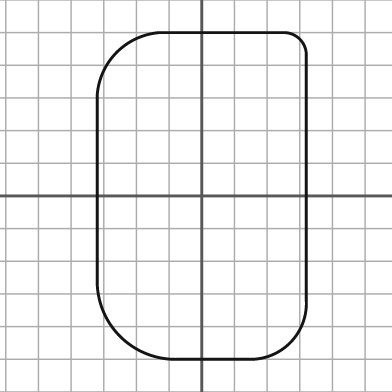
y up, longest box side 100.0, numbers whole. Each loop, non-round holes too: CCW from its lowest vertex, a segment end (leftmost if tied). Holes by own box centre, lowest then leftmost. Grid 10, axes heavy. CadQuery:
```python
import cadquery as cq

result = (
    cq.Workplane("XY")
    .moveTo(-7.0, -50.0)
    .lineTo(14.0, -50.0)
    .threePointArc((27.0, -45.0), (32.0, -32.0))
    .lineTo(32.0, 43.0)
    .threePointArc((30.0, 48.0), (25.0, 50.0))
    .lineTo(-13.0, 50.0)
    .threePointArc((-26.0, 44.0), (-32.0, 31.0))
    .lineTo(-32.0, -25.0)
    .threePointArc((-25.0, -43.0), (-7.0, -50.0))
    .close()
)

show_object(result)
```